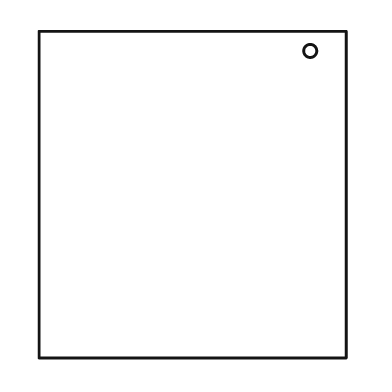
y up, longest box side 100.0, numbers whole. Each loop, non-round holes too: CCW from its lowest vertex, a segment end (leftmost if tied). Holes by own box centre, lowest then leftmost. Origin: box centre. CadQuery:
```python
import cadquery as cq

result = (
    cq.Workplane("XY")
    .moveTo(-47.0, -50.0)
    .lineTo(47.0, -50.0)
    .lineTo(47.0, 50.0)
    .lineTo(-47.0, 50.0)
    .close()
    .moveTo(36.0, 44.0)
    .circle(2.0)
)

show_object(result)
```